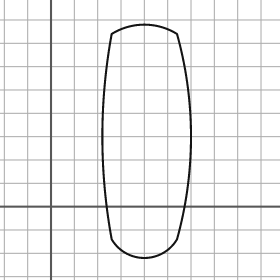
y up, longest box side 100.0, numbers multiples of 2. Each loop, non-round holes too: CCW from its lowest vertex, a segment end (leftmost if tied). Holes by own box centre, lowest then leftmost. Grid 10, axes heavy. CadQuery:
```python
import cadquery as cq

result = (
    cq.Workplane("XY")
    .moveTo(26.0, -14.0)
    .threePointArc((40.0, -22.0), (54.0, -14.0))
    .threePointArc((60.0, 30.0), (54.0, 74.0))
    .threePointArc((40.0, 78.0), (26.0, 74.0))
    .threePointArc((22.0, 30.0), (26.0, -14.0))
    .close()
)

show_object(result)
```